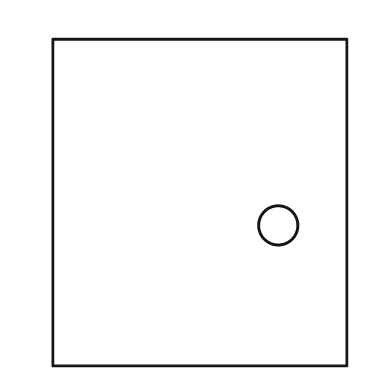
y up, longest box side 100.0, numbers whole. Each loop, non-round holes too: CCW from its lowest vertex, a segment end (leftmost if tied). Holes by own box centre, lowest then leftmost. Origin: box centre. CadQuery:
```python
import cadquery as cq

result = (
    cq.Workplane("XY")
    .moveTo(-45.0, -50.0)
    .lineTo(45.0, -50.0)
    .lineTo(45.0, 50.0)
    .lineTo(-45.0, 50.0)
    .close()
    .moveTo(24.0, -7.0)
    .circle(6.0)
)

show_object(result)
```